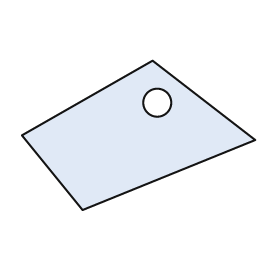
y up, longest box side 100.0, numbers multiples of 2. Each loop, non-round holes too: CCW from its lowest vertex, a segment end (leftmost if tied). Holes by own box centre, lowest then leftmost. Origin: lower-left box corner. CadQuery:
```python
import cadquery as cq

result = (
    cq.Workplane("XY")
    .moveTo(26.0, 0.0)
    .lineTo(100.0, 30.0)
    .lineTo(56.0, 64.0)
    .lineTo(0.0, 32.0)
    .close()
    .moveTo(58.0, 46.0)
    .circle(6.0)
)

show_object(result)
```